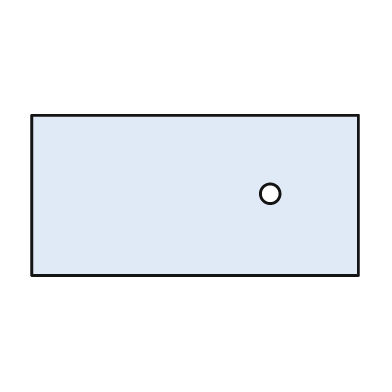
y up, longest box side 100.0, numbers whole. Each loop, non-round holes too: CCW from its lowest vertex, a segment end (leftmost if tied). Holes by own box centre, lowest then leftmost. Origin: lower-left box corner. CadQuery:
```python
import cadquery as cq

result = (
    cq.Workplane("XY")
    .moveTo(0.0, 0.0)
    .lineTo(100.0, 0.0)
    .lineTo(100.0, 49.0)
    .lineTo(0.0, 49.0)
    .close()
    .moveTo(73.0, 25.0)
    .circle(3.0)
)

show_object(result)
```